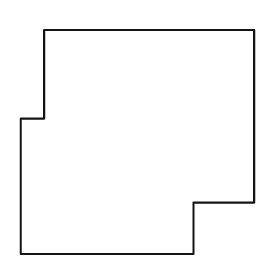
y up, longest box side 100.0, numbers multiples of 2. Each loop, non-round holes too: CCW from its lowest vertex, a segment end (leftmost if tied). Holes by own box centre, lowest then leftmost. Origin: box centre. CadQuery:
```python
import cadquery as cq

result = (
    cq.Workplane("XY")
    .moveTo(-50.0, -48.0)
    .lineTo(24.0, -48.0)
    .lineTo(24.0, -26.0)
    .lineTo(50.0, -26.0)
    .lineTo(50.0, 48.0)
    .lineTo(-40.0, 48.0)
    .lineTo(-40.0, 10.0)
    .lineTo(-50.0, 10.0)
    .close()
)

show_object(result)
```